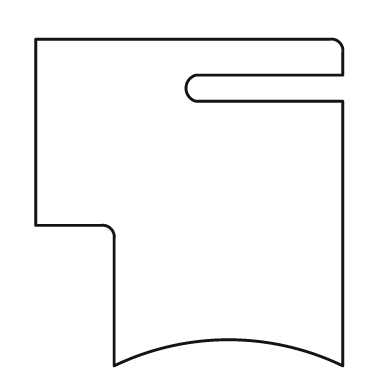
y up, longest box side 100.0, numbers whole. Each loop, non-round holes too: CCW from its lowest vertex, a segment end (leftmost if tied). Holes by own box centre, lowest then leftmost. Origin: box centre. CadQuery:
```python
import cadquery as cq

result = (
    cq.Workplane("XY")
    .moveTo(-23.0, -50.0)
    .threePointArc((12.0, -42.0), (47.0, -50.0))
    .lineTo(47.0, 31.0)
    .lineTo(2.0, 31.0)
    .threePointArc((-1.0, 35.0), (2.0, 39.0))
    .lineTo(47.0, 39.0)
    .lineTo(47.0, 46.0)
    .threePointArc((46.0, 49.0), (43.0, 50.0))
    .lineTo(-47.0, 50.0)
    .lineTo(-47.0, -7.0)
    .lineTo(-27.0, -7.0)
    .threePointArc((-24.0, -8.0), (-23.0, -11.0))
    .close()
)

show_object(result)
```